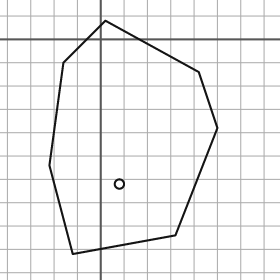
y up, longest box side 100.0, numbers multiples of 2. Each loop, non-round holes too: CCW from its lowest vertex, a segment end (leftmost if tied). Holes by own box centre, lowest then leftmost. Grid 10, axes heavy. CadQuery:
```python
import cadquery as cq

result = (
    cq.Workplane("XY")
    .moveTo(-12.0, -92.0)
    .lineTo(32.0, -84.0)
    .lineTo(50.0, -38.0)
    .lineTo(42.0, -14.0)
    .lineTo(2.0, 8.0)
    .lineTo(-16.0, -10.0)
    .lineTo(-22.0, -54.0)
    .close()
    .moveTo(8.0, -62.0)
    .circle(2.0)
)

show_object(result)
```